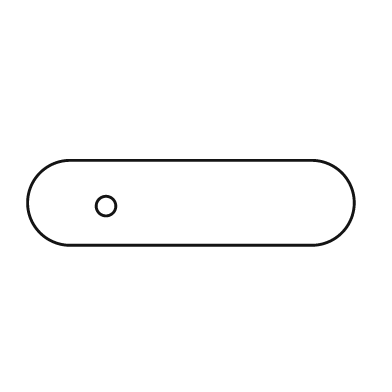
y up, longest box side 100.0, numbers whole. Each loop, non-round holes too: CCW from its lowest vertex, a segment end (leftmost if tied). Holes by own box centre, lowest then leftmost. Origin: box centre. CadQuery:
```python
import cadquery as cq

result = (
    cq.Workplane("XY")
    .moveTo(-37.0, -13.0)
    .lineTo(37.0, -13.0)
    .threePointArc((50.0, 0.0), (37.0, 13.0))
    .lineTo(-37.0, 13.0)
    .threePointArc((-50.0, 0.0), (-37.0, -13.0))
    .close()
    .moveTo(-26.0, -1.0)
    .circle(3.0)
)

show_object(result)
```